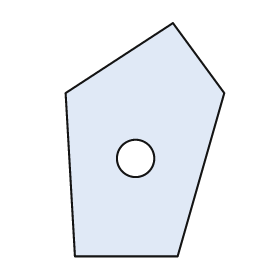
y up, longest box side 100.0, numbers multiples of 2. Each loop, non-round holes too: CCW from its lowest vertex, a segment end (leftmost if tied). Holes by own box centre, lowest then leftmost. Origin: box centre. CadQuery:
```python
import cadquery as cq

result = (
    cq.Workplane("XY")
    .moveTo(-30.0, -50.0)
    .lineTo(14.0, -50.0)
    .lineTo(34.0, 20.0)
    .lineTo(12.0, 50.0)
    .lineTo(-34.0, 20.0)
    .close()
    .moveTo(-4.0, -8.0)
    .circle(8.0)
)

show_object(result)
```